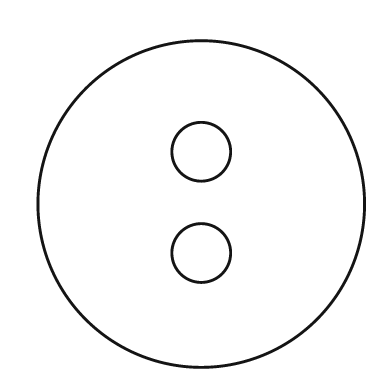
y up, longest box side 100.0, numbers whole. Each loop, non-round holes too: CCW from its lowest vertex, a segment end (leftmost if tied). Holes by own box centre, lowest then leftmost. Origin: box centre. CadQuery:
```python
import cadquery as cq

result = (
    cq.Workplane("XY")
    .moveTo(0.0, 0.0)
    .circle(50.0)
    .moveTo(0.0, -15.0)
    .circle(9.0)
    .moveTo(0.0, 16.0)
    .circle(9.0)
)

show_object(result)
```